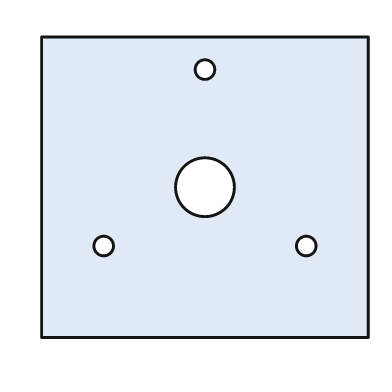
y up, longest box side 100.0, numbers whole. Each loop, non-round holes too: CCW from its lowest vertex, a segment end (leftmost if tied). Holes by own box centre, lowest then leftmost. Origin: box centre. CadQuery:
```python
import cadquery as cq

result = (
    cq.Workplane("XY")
    .moveTo(-50.0, -46.0)
    .lineTo(50.0, -46.0)
    .lineTo(50.0, 46.0)
    .lineTo(-50.0, 46.0)
    .close()
    .moveTo(-31.0, -18.0)
    .circle(3.0)
    .moveTo(31.0, -18.0)
    .circle(3.0)
    .moveTo(0.0, 0.0)
    .circle(9.0)
    .moveTo(0.0, 36.0)
    .circle(3.0)
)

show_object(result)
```